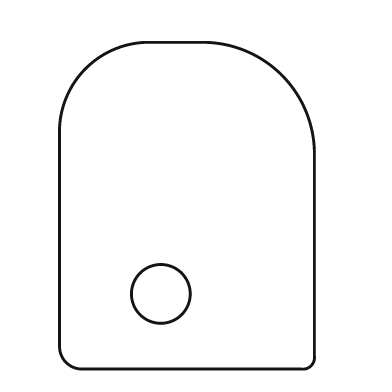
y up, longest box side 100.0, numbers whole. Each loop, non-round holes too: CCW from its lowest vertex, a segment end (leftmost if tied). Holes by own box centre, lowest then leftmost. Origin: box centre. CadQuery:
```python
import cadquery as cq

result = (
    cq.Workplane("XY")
    .moveTo(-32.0, -50.0)
    .lineTo(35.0, -50.0)
    .threePointArc((38.0, -49.0), (39.0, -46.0))
    .lineTo(39.0, 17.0)
    .threePointArc((29.0, 40.0), (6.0, 50.0))
    .lineTo(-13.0, 50.0)
    .threePointArc((-31.0, 42.0), (-39.0, 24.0))
    .lineTo(-39.0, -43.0)
    .threePointArc((-37.0, -48.0), (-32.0, -50.0))
    .close()
    .moveTo(-8.0, -27.0)
    .circle(9.0)
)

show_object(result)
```